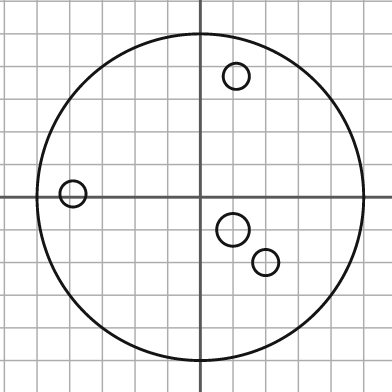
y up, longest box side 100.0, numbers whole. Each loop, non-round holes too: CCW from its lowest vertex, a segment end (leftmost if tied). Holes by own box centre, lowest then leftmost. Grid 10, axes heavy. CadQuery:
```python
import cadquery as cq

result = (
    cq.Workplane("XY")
    .moveTo(0.0, 0.0)
    .circle(50.0)
    .moveTo(20.0, -20.0)
    .circle(4.0)
    .moveTo(10.0, -10.0)
    .circle(5.0)
    .moveTo(-39.0, 1.0)
    .circle(4.0)
    .moveTo(11.0, 37.0)
    .circle(4.0)
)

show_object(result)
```